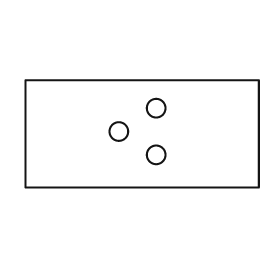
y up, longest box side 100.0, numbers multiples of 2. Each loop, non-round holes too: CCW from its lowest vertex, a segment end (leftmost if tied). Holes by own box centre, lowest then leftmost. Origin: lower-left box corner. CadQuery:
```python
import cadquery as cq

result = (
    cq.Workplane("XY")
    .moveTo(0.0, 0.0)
    .lineTo(100.0, 0.0)
    .lineTo(100.0, 46.0)
    .lineTo(0.0, 46.0)
    .close()
    .moveTo(56.0, 14.0)
    .circle(4.0)
    .moveTo(40.0, 24.0)
    .circle(4.0)
    .moveTo(56.0, 34.0)
    .circle(4.0)
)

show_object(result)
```